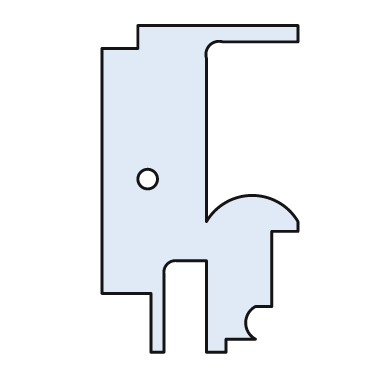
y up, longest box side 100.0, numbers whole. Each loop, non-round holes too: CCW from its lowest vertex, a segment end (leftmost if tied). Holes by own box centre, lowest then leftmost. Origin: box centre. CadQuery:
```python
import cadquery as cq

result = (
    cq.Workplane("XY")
    .moveTo(-15.0, -50.0)
    .lineTo(-11.0, -50.0)
    .lineTo(-11.0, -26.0)
    .threePointArc((-10.0, -23.0), (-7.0, -22.0))
    .lineTo(2.0, -22.0)
    .lineTo(2.0, -50.0)
    .lineTo(8.0, -50.0)
    .lineTo(8.0, -46.0)
    .lineTo(17.0, -46.0)
    .threePointArc((14.0, -41.0), (17.0, -36.0))
    .lineTo(22.0, -36.0)
    .lineTo(22.0, -13.0)
    .lineTo(30.0, -13.0)
    .lineTo(30.0, -10.0)
    .threePointArc((16.0, -2.0), (2.0, -10.0))
    .lineTo(2.0, 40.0)
    .threePointArc((3.0, 44.0), (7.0, 45.0))
    .lineTo(30.0, 45.0)
    .lineTo(30.0, 50.0)
    .lineTo(-19.0, 50.0)
    .lineTo(-19.0, 43.0)
    .lineTo(-30.0, 43.0)
    .lineTo(-30.0, -32.0)
    .lineTo(-15.0, -32.0)
    .close()
    .moveTo(-16.0, 3.0)
    .circle(3.0)
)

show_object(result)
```